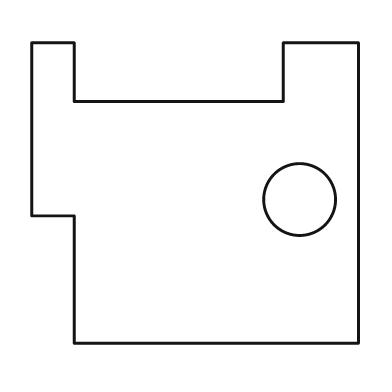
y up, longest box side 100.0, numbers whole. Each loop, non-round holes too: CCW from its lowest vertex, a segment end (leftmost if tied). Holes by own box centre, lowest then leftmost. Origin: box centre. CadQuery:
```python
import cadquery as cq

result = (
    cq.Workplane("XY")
    .moveTo(-37.0, -46.0)
    .lineTo(50.0, -46.0)
    .lineTo(50.0, 46.0)
    .lineTo(27.0, 46.0)
    .lineTo(27.0, 28.0)
    .lineTo(-37.0, 28.0)
    .lineTo(-37.0, 46.0)
    .lineTo(-50.0, 46.0)
    .lineTo(-50.0, -7.0)
    .lineTo(-37.0, -7.0)
    .close()
    .moveTo(32.0, -2.0)
    .circle(11.0)
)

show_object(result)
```